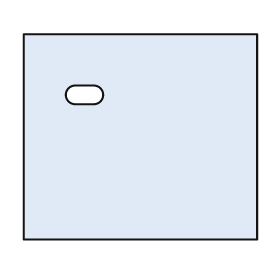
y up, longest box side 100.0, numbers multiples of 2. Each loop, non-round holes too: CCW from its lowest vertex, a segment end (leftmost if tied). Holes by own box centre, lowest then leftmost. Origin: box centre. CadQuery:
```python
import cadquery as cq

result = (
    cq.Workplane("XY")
    .moveTo(-50.0, -44.0)
    .lineTo(50.0, -44.0)
    .lineTo(50.0, 44.0)
    .lineTo(-50.0, 44.0)
    .close()
    .moveTo(-28.0, 14.0)
    .lineTo(-20.0, 14.0)
    .threePointArc((-16.0, 18.0), (-20.0, 22.0))
    .lineTo(-28.0, 22.0)
    .threePointArc((-32.0, 18.0), (-28.0, 14.0))
    .close()
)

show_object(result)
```